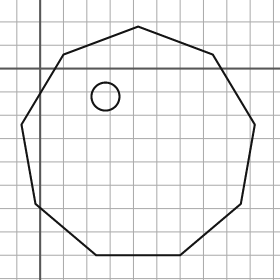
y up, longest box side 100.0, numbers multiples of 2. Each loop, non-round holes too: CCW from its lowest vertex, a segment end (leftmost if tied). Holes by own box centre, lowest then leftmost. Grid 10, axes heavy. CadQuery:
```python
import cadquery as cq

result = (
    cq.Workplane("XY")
    .moveTo(24.0, -80.0)
    .lineTo(60.0, -80.0)
    .lineTo(86.0, -58.0)
    .lineTo(92.0, -24.0)
    .lineTo(74.0, 6.0)
    .lineTo(42.0, 18.0)
    .lineTo(10.0, 6.0)
    .lineTo(-8.0, -24.0)
    .lineTo(-2.0, -58.0)
    .close()
    .moveTo(28.0, -12.0)
    .circle(6.0)
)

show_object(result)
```